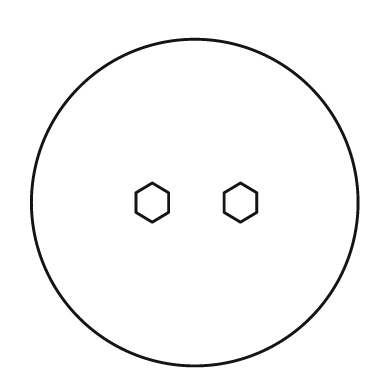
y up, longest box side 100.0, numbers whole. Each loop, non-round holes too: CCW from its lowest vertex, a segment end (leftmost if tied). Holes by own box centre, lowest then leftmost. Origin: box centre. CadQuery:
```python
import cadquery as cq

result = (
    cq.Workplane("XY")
    .moveTo(0.0, 0.0)
    .circle(50.0)
    .moveTo(-13.0, -6.0)
    .lineTo(-8.0, -3.0)
    .lineTo(-8.0, 3.0)
    .lineTo(-13.0, 6.0)
    .lineTo(-18.0, 3.0)
    .lineTo(-18.0, -3.0)
    .close()
    .moveTo(14.0, -6.0)
    .lineTo(19.0, -3.0)
    .lineTo(19.0, 3.0)
    .lineTo(14.0, 6.0)
    .lineTo(9.0, 3.0)
    .lineTo(9.0, -3.0)
    .close()
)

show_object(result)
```